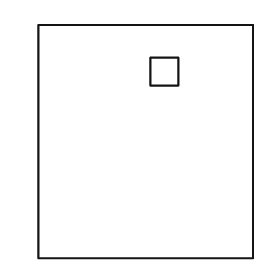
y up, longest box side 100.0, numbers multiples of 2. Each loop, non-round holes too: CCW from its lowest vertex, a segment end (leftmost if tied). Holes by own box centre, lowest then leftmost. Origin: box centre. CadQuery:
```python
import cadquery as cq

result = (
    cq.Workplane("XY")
    .moveTo(-46.0, -50.0)
    .lineTo(46.0, -50.0)
    .lineTo(46.0, 50.0)
    .lineTo(-46.0, 50.0)
    .close()
    .moveTo(2.0, 24.0)
    .lineTo(14.0, 24.0)
    .lineTo(14.0, 36.0)
    .lineTo(2.0, 36.0)
    .close()
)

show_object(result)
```